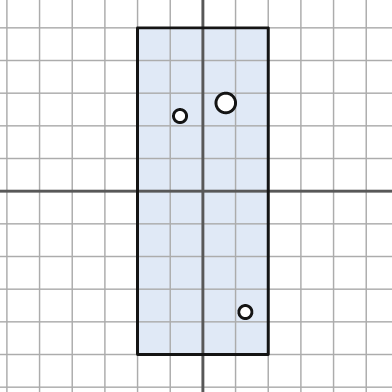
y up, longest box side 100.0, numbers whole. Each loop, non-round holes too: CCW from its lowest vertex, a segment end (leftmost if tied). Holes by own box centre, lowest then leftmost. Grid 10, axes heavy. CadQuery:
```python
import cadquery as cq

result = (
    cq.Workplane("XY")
    .moveTo(-20.0, -50.0)
    .lineTo(20.0, -50.0)
    .lineTo(20.0, 50.0)
    .lineTo(-20.0, 50.0)
    .close()
    .moveTo(13.0, -37.0)
    .circle(2.0)
    .moveTo(-7.0, 23.0)
    .circle(2.0)
    .moveTo(7.0, 27.0)
    .circle(3.0)
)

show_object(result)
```